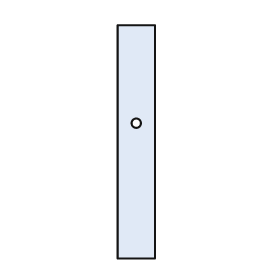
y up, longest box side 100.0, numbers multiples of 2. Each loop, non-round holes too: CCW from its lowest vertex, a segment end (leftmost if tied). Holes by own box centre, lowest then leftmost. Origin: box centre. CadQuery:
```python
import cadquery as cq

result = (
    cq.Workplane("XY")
    .moveTo(-8.0, -50.0)
    .lineTo(8.0, -50.0)
    .lineTo(8.0, 50.0)
    .lineTo(-8.0, 50.0)
    .close()
    .moveTo(0.0, 8.0)
    .circle(2.0)
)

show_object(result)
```